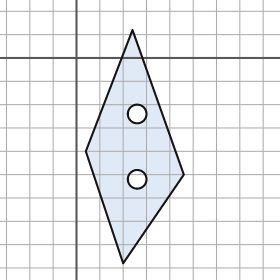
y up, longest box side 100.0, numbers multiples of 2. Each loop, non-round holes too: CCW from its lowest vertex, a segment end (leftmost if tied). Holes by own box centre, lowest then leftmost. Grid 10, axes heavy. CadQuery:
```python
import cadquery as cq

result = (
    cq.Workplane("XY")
    .moveTo(20.0, -88.0)
    .lineTo(46.0, -50.0)
    .lineTo(24.0, 12.0)
    .lineTo(4.0, -40.0)
    .close()
    .moveTo(26.0, -52.0)
    .circle(4.0)
    .moveTo(26.0, -24.0)
    .circle(4.0)
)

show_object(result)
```